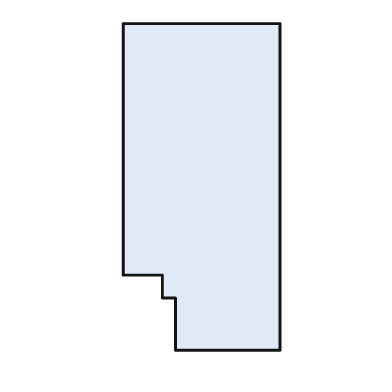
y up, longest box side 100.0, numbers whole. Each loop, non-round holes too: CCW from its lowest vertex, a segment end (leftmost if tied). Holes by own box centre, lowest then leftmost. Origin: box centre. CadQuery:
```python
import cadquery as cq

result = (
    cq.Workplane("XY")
    .moveTo(-8.0, -50.0)
    .lineTo(24.0, -50.0)
    .lineTo(24.0, 50.0)
    .lineTo(-24.0, 50.0)
    .lineTo(-24.0, -27.0)
    .lineTo(-12.0, -27.0)
    .lineTo(-12.0, -34.0)
    .lineTo(-8.0, -34.0)
    .close()
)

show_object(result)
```